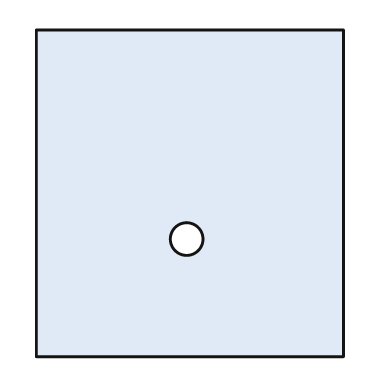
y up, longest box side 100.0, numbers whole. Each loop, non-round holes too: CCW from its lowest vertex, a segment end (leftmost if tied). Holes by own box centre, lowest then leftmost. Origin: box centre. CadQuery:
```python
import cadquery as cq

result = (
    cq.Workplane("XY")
    .moveTo(-47.0, -50.0)
    .lineTo(47.0, -50.0)
    .lineTo(47.0, 50.0)
    .lineTo(-47.0, 50.0)
    .close()
    .moveTo(-1.0, -14.0)
    .circle(5.0)
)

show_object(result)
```